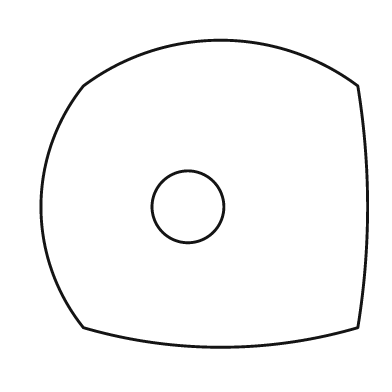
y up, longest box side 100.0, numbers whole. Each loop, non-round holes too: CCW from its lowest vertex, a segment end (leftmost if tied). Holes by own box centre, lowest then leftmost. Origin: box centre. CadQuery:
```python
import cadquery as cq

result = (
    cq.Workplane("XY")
    .moveTo(-37.0, -41.0)
    .threePointArc((5.0, -47.0), (47.0, -41.0))
    .threePointArc((50.0, -4.0), (47.0, 33.0))
    .threePointArc((5.0, 47.0), (-37.0, 33.0))
    .threePointArc((-50.0, -4.0), (-37.0, -41.0))
    .close()
    .moveTo(-5.0, -4.0)
    .circle(11.0)
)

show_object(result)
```